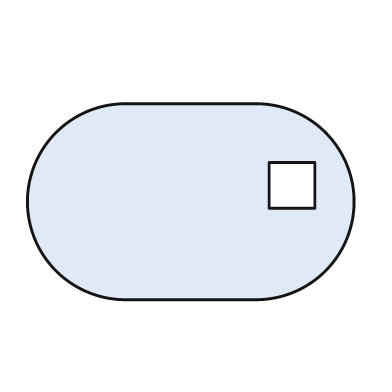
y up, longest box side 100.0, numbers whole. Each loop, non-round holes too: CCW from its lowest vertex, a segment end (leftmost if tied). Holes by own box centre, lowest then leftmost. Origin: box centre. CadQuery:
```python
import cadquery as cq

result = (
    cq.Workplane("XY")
    .moveTo(-20.0, -30.0)
    .lineTo(20.0, -30.0)
    .threePointArc((50.0, 0.0), (20.0, 30.0))
    .lineTo(-20.0, 30.0)
    .threePointArc((-50.0, 0.0), (-20.0, -30.0))
    .close()
    .moveTo(24.0, -2.0)
    .lineTo(38.0, -2.0)
    .lineTo(38.0, 12.0)
    .lineTo(24.0, 12.0)
    .close()
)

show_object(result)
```